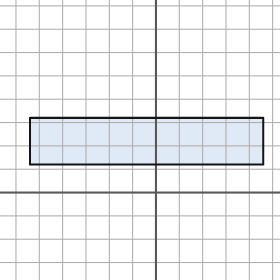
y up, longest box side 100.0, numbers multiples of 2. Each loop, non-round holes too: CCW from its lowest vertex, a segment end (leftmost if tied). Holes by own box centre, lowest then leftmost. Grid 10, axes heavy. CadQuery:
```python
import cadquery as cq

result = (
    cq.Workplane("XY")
    .moveTo(-54.0, 12.0)
    .lineTo(46.0, 12.0)
    .lineTo(46.0, 32.0)
    .lineTo(-54.0, 32.0)
    .close()
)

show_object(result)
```